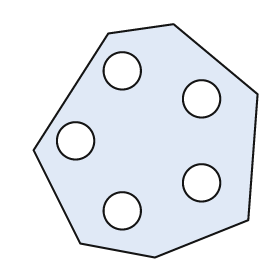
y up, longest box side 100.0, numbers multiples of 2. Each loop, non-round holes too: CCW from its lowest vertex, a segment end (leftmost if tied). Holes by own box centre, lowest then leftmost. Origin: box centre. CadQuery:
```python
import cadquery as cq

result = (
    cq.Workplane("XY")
    .moveTo(4.0, -50.0)
    .lineTo(44.0, -34.0)
    .lineTo(48.0, 20.0)
    .lineTo(12.0, 50.0)
    .lineTo(-16.0, 46.0)
    .lineTo(-48.0, -4.0)
    .lineTo(-28.0, -44.0)
    .close()
    .moveTo(-10.0, -30.0)
    .circle(8.0)
    .moveTo(24.0, -18.0)
    .circle(8.0)
    .moveTo(-30.0, 0.0)
    .circle(8.0)
    .moveTo(24.0, 18.0)
    .circle(8.0)
    .moveTo(-10.0, 30.0)
    .circle(8.0)
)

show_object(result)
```